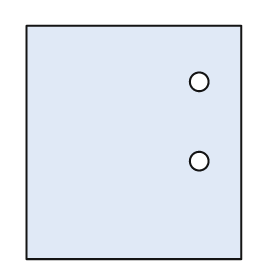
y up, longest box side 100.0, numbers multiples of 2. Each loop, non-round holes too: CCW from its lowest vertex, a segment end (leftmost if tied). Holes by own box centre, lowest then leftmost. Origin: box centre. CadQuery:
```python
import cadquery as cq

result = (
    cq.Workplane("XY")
    .moveTo(-46.0, -50.0)
    .lineTo(46.0, -50.0)
    .lineTo(46.0, 50.0)
    .lineTo(-46.0, 50.0)
    .close()
    .moveTo(28.0, -8.0)
    .circle(4.0)
    .moveTo(28.0, 26.0)
    .circle(4.0)
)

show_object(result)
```